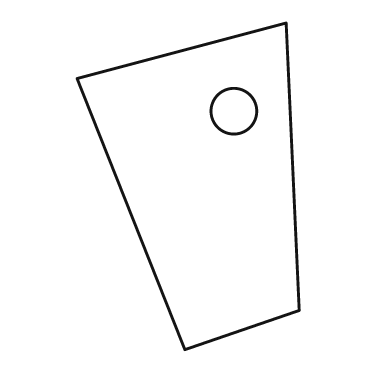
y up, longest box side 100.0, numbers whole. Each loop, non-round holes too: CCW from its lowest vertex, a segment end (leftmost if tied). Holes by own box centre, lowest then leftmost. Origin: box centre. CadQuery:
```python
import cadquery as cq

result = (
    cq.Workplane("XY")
    .moveTo(-1.0, -50.0)
    .lineTo(34.0, -38.0)
    .lineTo(30.0, 50.0)
    .lineTo(-34.0, 33.0)
    .close()
    .moveTo(14.0, 23.0)
    .circle(7.0)
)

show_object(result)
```